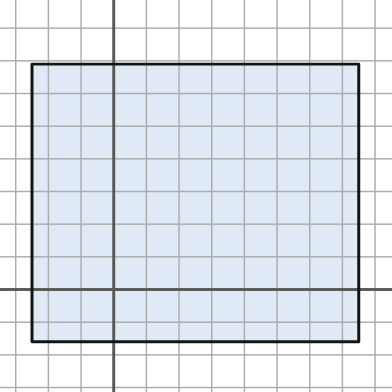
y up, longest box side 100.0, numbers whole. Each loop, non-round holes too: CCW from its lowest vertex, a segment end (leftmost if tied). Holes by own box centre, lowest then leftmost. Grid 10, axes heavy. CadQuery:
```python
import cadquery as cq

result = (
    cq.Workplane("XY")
    .moveTo(-25.0, -16.0)
    .lineTo(75.0, -16.0)
    .lineTo(75.0, 69.0)
    .lineTo(-25.0, 69.0)
    .close()
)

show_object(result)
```